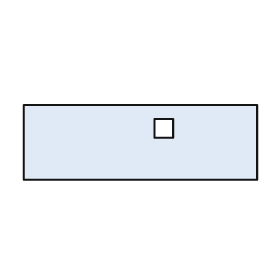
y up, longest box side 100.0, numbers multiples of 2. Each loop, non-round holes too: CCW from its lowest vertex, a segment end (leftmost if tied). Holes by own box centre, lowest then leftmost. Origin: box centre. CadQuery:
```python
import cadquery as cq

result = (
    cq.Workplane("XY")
    .moveTo(-50.0, -16.0)
    .lineTo(50.0, -16.0)
    .lineTo(50.0, 16.0)
    .lineTo(-50.0, 16.0)
    .close()
    .moveTo(6.0, 2.0)
    .lineTo(14.0, 2.0)
    .lineTo(14.0, 10.0)
    .lineTo(6.0, 10.0)
    .close()
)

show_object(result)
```